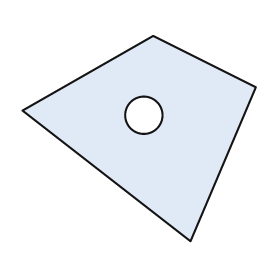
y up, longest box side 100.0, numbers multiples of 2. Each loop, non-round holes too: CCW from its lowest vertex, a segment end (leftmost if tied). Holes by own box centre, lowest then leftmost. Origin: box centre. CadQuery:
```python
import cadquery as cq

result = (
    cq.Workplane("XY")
    .moveTo(22.0, -44.0)
    .lineTo(50.0, 22.0)
    .lineTo(6.0, 44.0)
    .lineTo(-50.0, 12.0)
    .close()
    .moveTo(2.0, 10.0)
    .circle(8.0)
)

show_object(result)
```